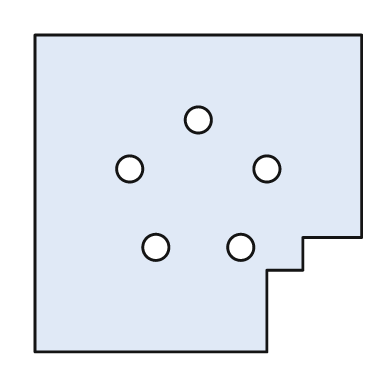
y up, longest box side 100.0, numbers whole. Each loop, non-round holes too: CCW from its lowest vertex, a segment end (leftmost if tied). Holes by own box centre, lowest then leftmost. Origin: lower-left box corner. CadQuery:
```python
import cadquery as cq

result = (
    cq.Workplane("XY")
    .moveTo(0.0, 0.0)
    .lineTo(71.0, 0.0)
    .lineTo(71.0, 25.0)
    .lineTo(82.0, 25.0)
    .lineTo(82.0, 35.0)
    .lineTo(100.0, 35.0)
    .lineTo(100.0, 97.0)
    .lineTo(0.0, 97.0)
    .close()
    .moveTo(37.0, 32.0)
    .circle(4.0)
    .moveTo(63.0, 32.0)
    .circle(4.0)
    .moveTo(29.0, 56.0)
    .circle(4.0)
    .moveTo(71.0, 56.0)
    .circle(4.0)
    .moveTo(50.0, 71.0)
    .circle(4.0)
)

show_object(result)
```